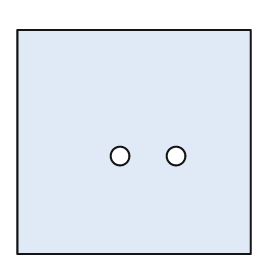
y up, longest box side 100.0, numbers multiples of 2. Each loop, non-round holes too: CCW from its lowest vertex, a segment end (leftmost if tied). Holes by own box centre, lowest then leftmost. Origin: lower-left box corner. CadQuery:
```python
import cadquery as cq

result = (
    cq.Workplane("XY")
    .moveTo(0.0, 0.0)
    .lineTo(100.0, 0.0)
    .lineTo(100.0, 96.0)
    .lineTo(0.0, 96.0)
    .close()
    .moveTo(44.0, 42.0)
    .circle(4.0)
    .moveTo(68.0, 42.0)
    .circle(4.0)
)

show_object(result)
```